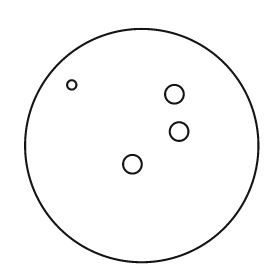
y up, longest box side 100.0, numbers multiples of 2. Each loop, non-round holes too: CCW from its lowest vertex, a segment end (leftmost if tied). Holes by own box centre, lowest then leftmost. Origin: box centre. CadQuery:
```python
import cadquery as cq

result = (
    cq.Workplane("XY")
    .moveTo(0.0, 0.0)
    .circle(50.0)
    .moveTo(-4.0, -8.0)
    .circle(4.0)
    .moveTo(16.0, 6.0)
    .circle(4.0)
    .moveTo(14.0, 22.0)
    .circle(4.0)
    .moveTo(-30.0, 26.0)
    .circle(2.0)
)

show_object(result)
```